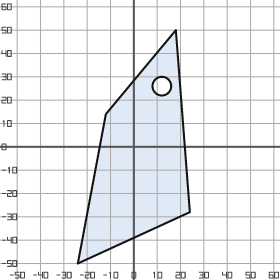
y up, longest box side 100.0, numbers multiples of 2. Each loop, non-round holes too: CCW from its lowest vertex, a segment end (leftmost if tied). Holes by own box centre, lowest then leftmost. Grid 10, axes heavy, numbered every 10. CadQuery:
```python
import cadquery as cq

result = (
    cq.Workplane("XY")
    .moveTo(-24.0, -50.0)
    .lineTo(24.0, -28.0)
    .lineTo(18.0, 50.0)
    .lineTo(-12.0, 14.0)
    .close()
    .moveTo(12.0, 26.0)
    .circle(4.0)
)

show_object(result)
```